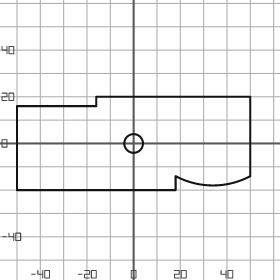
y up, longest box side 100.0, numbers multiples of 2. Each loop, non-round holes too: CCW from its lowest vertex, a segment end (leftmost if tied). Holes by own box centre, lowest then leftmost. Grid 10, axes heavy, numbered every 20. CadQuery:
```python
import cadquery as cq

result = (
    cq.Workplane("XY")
    .moveTo(-50.0, -20.0)
    .lineTo(18.0, -20.0)
    .lineTo(18.0, -14.0)
    .threePointArc((34.0, -18.0), (50.0, -14.0))
    .lineTo(50.0, 20.0)
    .lineTo(-16.0, 20.0)
    .lineTo(-16.0, 16.0)
    .lineTo(-50.0, 16.0)
    .close()
    .moveTo(0.0, 0.0)
    .circle(4.0)
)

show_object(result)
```